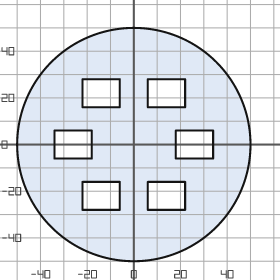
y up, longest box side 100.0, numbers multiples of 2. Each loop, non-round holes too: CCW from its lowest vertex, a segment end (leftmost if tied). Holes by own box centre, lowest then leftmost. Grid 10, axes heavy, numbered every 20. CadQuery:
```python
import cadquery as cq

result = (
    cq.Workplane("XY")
    .moveTo(0.0, 0.0)
    .circle(50.0)
    .moveTo(-22.0, -28.0)
    .lineTo(-6.0, -28.0)
    .lineTo(-6.0, -16.0)
    .lineTo(-22.0, -16.0)
    .close()
    .moveTo(6.0, -28.0)
    .lineTo(22.0, -28.0)
    .lineTo(22.0, -16.0)
    .lineTo(6.0, -16.0)
    .close()
    .moveTo(-34.0, -6.0)
    .lineTo(-18.0, -6.0)
    .lineTo(-18.0, 6.0)
    .lineTo(-34.0, 6.0)
    .close()
    .moveTo(18.0, -6.0)
    .lineTo(34.0, -6.0)
    .lineTo(34.0, 6.0)
    .lineTo(18.0, 6.0)
    .close()
    .moveTo(-22.0, 16.0)
    .lineTo(-6.0, 16.0)
    .lineTo(-6.0, 28.0)
    .lineTo(-22.0, 28.0)
    .close()
    .moveTo(6.0, 16.0)
    .lineTo(22.0, 16.0)
    .lineTo(22.0, 28.0)
    .lineTo(6.0, 28.0)
    .close()
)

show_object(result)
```